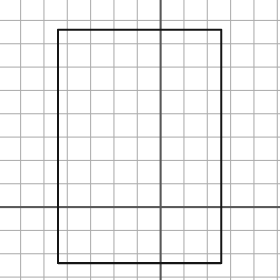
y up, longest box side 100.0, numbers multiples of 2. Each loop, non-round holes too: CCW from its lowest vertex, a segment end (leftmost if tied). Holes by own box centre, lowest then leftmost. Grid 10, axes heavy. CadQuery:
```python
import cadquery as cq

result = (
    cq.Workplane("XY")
    .moveTo(-44.0, -24.0)
    .lineTo(26.0, -24.0)
    .lineTo(26.0, 76.0)
    .lineTo(-44.0, 76.0)
    .close()
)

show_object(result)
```